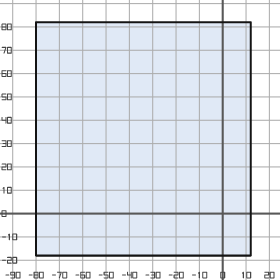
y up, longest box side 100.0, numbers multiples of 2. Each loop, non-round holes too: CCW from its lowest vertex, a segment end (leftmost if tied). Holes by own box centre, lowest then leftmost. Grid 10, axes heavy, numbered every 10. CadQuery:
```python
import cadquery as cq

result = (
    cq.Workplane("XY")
    .moveTo(-80.0, -18.0)
    .lineTo(12.0, -18.0)
    .lineTo(12.0, 82.0)
    .lineTo(-80.0, 82.0)
    .close()
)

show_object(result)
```